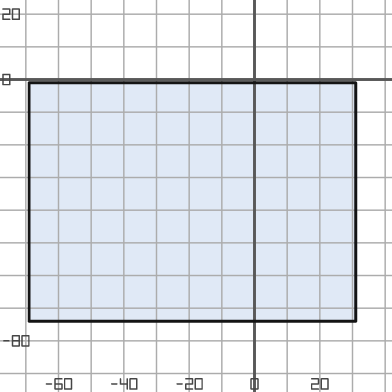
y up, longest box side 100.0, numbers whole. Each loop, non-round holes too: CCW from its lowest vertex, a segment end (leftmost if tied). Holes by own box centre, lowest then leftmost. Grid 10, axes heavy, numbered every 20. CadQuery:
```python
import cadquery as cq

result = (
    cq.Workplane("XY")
    .moveTo(-69.0, -74.0)
    .lineTo(31.0, -74.0)
    .lineTo(31.0, -1.0)
    .lineTo(-69.0, -1.0)
    .close()
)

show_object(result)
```